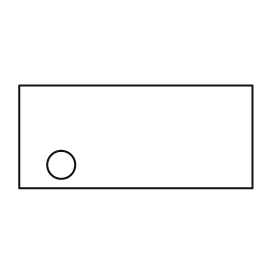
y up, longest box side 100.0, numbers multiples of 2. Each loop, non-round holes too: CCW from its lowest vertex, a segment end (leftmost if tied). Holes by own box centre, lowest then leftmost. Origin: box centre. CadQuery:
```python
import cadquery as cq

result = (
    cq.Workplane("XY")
    .moveTo(-50.0, -22.0)
    .lineTo(50.0, -22.0)
    .lineTo(50.0, 22.0)
    .lineTo(-50.0, 22.0)
    .close()
    .moveTo(-32.0, -12.0)
    .circle(6.0)
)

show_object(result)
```